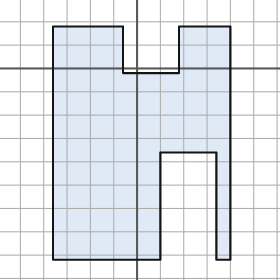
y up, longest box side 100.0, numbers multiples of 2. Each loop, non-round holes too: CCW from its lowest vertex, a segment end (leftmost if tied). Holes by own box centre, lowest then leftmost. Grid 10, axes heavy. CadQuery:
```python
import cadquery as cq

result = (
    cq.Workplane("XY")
    .moveTo(-36.0, -82.0)
    .lineTo(10.0, -82.0)
    .lineTo(10.0, -36.0)
    .lineTo(34.0, -36.0)
    .lineTo(34.0, -82.0)
    .lineTo(40.0, -82.0)
    .lineTo(40.0, 18.0)
    .lineTo(18.0, 18.0)
    .lineTo(18.0, -2.0)
    .lineTo(-6.0, -2.0)
    .lineTo(-6.0, 18.0)
    .lineTo(-36.0, 18.0)
    .close()
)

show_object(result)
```